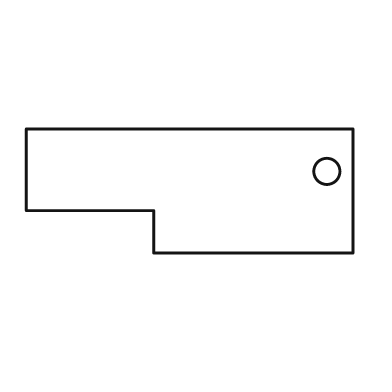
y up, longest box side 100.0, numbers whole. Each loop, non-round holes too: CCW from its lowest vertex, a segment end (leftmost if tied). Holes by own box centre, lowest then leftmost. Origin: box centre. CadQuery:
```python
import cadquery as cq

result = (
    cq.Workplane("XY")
    .moveTo(-11.0, -19.0)
    .lineTo(50.0, -19.0)
    .lineTo(50.0, 19.0)
    .lineTo(-50.0, 19.0)
    .lineTo(-50.0, -6.0)
    .lineTo(-11.0, -6.0)
    .close()
    .moveTo(42.0, 6.0)
    .circle(4.0)
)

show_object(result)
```